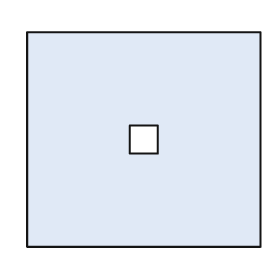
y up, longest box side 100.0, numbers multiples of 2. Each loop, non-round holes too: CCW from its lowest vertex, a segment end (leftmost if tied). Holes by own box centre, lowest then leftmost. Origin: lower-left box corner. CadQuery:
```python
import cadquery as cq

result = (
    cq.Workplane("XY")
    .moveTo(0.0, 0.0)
    .lineTo(100.0, 0.0)
    .lineTo(100.0, 92.0)
    .lineTo(0.0, 92.0)
    .close()
    .moveTo(44.0, 40.0)
    .lineTo(56.0, 40.0)
    .lineTo(56.0, 52.0)
    .lineTo(44.0, 52.0)
    .close()
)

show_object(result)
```